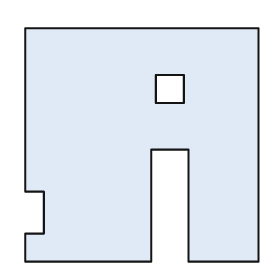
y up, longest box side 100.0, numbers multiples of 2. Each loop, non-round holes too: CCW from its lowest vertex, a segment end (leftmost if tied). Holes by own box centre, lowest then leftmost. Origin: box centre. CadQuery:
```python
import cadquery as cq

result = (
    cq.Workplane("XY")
    .moveTo(-50.0, -50.0)
    .lineTo(4.0, -50.0)
    .lineTo(4.0, -2.0)
    .lineTo(20.0, -2.0)
    .lineTo(20.0, -50.0)
    .lineTo(50.0, -50.0)
    .lineTo(50.0, 50.0)
    .lineTo(-50.0, 50.0)
    .lineTo(-50.0, -20.0)
    .lineTo(-42.0, -20.0)
    .lineTo(-42.0, -38.0)
    .lineTo(-50.0, -38.0)
    .close()
    .moveTo(6.0, 18.0)
    .lineTo(18.0, 18.0)
    .lineTo(18.0, 30.0)
    .lineTo(6.0, 30.0)
    .close()
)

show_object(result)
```